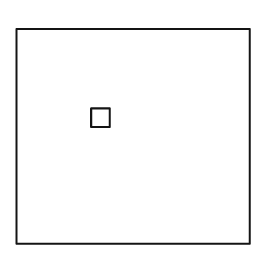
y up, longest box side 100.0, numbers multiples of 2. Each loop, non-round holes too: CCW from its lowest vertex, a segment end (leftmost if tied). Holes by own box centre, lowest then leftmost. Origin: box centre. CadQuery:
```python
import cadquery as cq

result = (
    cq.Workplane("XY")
    .moveTo(-50.0, -46.0)
    .lineTo(50.0, -46.0)
    .lineTo(50.0, 46.0)
    .lineTo(-50.0, 46.0)
    .close()
    .moveTo(-18.0, 4.0)
    .lineTo(-10.0, 4.0)
    .lineTo(-10.0, 12.0)
    .lineTo(-18.0, 12.0)
    .close()
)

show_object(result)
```